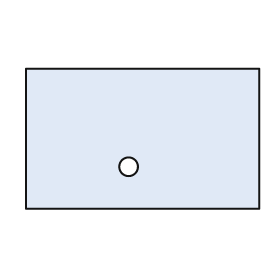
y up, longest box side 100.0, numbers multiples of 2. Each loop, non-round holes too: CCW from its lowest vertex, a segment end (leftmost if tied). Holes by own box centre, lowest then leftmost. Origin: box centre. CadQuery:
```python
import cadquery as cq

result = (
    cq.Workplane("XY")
    .moveTo(-50.0, -30.0)
    .lineTo(50.0, -30.0)
    .lineTo(50.0, 30.0)
    .lineTo(-50.0, 30.0)
    .close()
    .moveTo(-6.0, -12.0)
    .circle(4.0)
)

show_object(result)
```